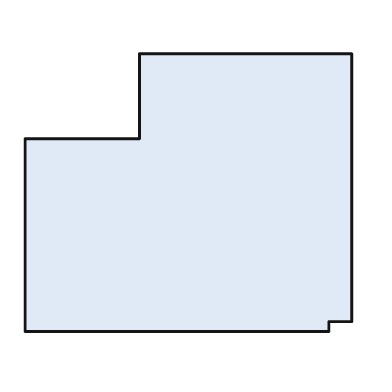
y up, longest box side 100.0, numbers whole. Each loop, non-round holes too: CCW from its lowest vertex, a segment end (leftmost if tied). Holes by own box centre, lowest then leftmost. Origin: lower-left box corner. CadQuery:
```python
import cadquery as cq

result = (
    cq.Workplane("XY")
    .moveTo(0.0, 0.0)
    .lineTo(93.0, 0.0)
    .lineTo(93.0, 3.0)
    .lineTo(100.0, 3.0)
    .lineTo(100.0, 85.0)
    .lineTo(35.0, 85.0)
    .lineTo(35.0, 59.0)
    .lineTo(0.0, 59.0)
    .close()
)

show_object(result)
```